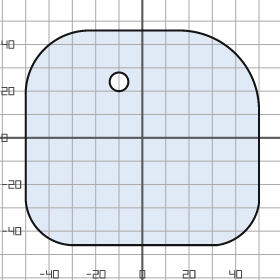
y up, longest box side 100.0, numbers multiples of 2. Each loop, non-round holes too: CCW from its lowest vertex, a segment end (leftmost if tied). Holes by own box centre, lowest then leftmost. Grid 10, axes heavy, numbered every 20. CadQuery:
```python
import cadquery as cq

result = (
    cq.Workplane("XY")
    .moveTo(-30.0, -46.0)
    .lineTo(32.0, -46.0)
    .threePointArc((44.0, -40.0), (50.0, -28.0))
    .lineTo(50.0, 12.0)
    .threePointArc((40.0, 36.0), (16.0, 46.0))
    .lineTo(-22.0, 46.0)
    .threePointArc((-42.0, 38.0), (-50.0, 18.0))
    .lineTo(-50.0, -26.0)
    .threePointArc((-44.0, -40.0), (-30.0, -46.0))
    .close()
    .moveTo(-10.0, 24.0)
    .circle(4.0)
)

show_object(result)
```